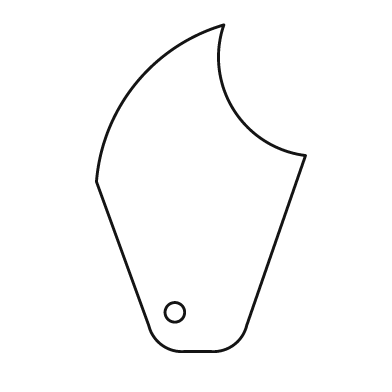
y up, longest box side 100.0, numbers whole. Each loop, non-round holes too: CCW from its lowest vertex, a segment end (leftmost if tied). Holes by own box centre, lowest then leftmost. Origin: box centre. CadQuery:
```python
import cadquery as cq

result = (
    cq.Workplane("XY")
    .moveTo(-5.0, -50.0)
    .lineTo(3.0, -50.0)
    .threePointArc((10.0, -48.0), (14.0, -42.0))
    .lineTo(32.0, 10.0)
    .threePointArc((10.0, 24.0), (7.0, 50.0))
    .threePointArc((-20.0, 32.0), (-32.0, 2.0))
    .lineTo(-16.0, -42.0)
    .threePointArc((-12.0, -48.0), (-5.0, -50.0))
    .close()
    .moveTo(-8.0, -38.0)
    .circle(3.0)
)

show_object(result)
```